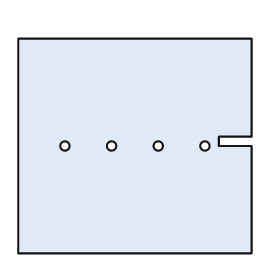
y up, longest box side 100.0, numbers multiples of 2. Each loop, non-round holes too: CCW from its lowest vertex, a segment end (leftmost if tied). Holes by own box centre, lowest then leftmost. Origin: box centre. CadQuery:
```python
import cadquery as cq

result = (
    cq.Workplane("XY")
    .moveTo(-50.0, -46.0)
    .lineTo(50.0, -46.0)
    .lineTo(50.0, 0.0)
    .lineTo(36.0, 0.0)
    .lineTo(36.0, 4.0)
    .lineTo(50.0, 4.0)
    .lineTo(50.0, 46.0)
    .lineTo(-50.0, 46.0)
    .close()
    .moveTo(-30.0, 0.0)
    .circle(2.0)
    .moveTo(-10.0, 0.0)
    .circle(2.0)
    .moveTo(10.0, 0.0)
    .circle(2.0)
    .moveTo(30.0, 0.0)
    .circle(2.0)
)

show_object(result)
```